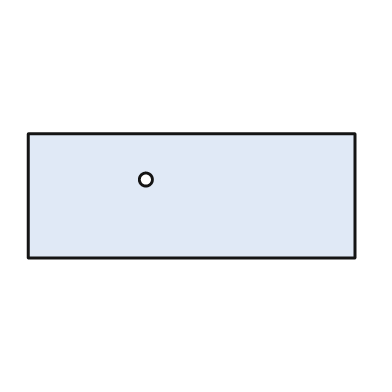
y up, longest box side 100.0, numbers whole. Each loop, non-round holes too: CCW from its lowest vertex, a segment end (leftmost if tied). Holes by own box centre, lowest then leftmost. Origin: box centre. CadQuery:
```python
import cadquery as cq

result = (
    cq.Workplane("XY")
    .moveTo(-50.0, -19.0)
    .lineTo(50.0, -19.0)
    .lineTo(50.0, 19.0)
    .lineTo(-50.0, 19.0)
    .close()
    .moveTo(-14.0, 5.0)
    .circle(2.0)
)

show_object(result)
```